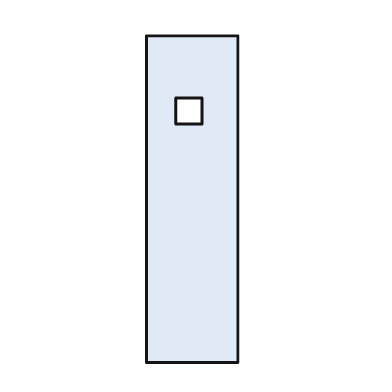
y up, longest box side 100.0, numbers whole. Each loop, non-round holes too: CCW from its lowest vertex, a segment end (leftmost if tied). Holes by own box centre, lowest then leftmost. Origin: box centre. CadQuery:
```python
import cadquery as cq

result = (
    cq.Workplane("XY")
    .moveTo(-14.0, -50.0)
    .lineTo(14.0, -50.0)
    .lineTo(14.0, 50.0)
    .lineTo(-14.0, 50.0)
    .close()
    .moveTo(-5.0, 23.0)
    .lineTo(3.0, 23.0)
    .lineTo(3.0, 31.0)
    .lineTo(-5.0, 31.0)
    .close()
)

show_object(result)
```